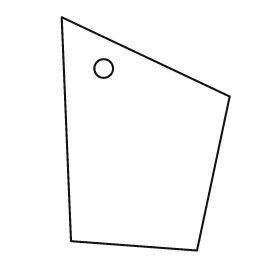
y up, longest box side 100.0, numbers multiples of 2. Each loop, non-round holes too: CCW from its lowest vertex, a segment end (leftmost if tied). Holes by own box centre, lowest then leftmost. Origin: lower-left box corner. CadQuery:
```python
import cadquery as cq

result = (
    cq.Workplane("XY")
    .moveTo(58.0, 0.0)
    .lineTo(72.0, 66.0)
    .lineTo(0.0, 100.0)
    .lineTo(4.0, 4.0)
    .close()
    .moveTo(18.0, 78.0)
    .circle(4.0)
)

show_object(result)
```